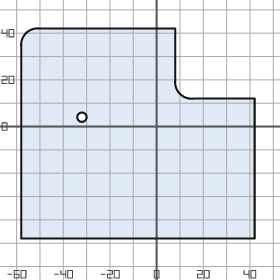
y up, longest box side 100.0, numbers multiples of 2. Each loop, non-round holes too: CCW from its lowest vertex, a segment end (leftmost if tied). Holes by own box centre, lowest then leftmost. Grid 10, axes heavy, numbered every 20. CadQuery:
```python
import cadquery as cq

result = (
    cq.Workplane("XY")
    .moveTo(-58.0, -48.0)
    .lineTo(42.0, -48.0)
    .lineTo(42.0, 12.0)
    .lineTo(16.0, 12.0)
    .threePointArc((10.0, 14.0), (8.0, 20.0))
    .lineTo(8.0, 42.0)
    .lineTo(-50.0, 42.0)
    .threePointArc((-56.0, 40.0), (-58.0, 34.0))
    .close()
    .moveTo(-32.0, 4.0)
    .circle(2.0)
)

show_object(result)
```